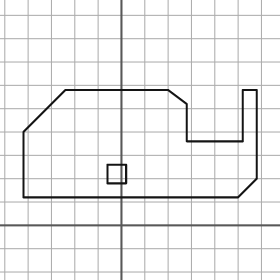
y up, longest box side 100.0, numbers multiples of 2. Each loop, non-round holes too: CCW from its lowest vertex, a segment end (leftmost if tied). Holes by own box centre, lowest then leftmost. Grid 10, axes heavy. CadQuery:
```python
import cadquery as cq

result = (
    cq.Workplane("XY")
    .moveTo(-42.0, 12.0)
    .lineTo(50.0, 12.0)
    .lineTo(58.0, 20.0)
    .lineTo(58.0, 58.0)
    .lineTo(52.0, 58.0)
    .lineTo(52.0, 36.0)
    .lineTo(28.0, 36.0)
    .lineTo(28.0, 52.0)
    .lineTo(20.0, 58.0)
    .lineTo(-24.0, 58.0)
    .lineTo(-42.0, 40.0)
    .close()
    .moveTo(-6.0, 18.0)
    .lineTo(2.0, 18.0)
    .lineTo(2.0, 26.0)
    .lineTo(-6.0, 26.0)
    .close()
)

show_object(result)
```